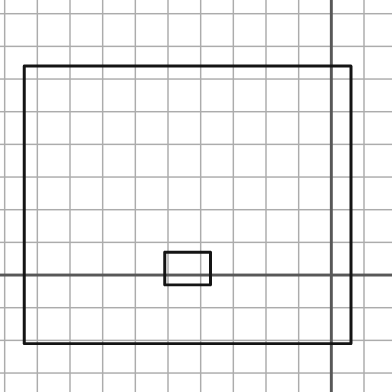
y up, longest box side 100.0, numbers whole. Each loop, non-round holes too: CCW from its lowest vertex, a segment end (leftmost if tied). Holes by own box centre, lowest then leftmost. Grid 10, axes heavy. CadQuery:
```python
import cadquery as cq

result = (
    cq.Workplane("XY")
    .moveTo(-94.0, -21.0)
    .lineTo(6.0, -21.0)
    .lineTo(6.0, 64.0)
    .lineTo(-94.0, 64.0)
    .close()
    .moveTo(-51.0, -3.0)
    .lineTo(-37.0, -3.0)
    .lineTo(-37.0, 7.0)
    .lineTo(-51.0, 7.0)
    .close()
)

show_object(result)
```